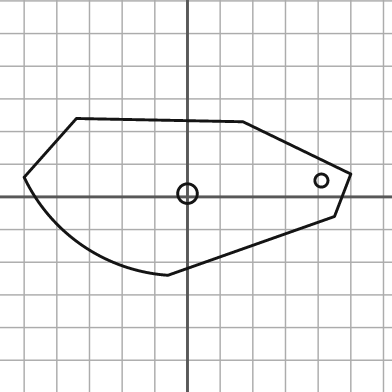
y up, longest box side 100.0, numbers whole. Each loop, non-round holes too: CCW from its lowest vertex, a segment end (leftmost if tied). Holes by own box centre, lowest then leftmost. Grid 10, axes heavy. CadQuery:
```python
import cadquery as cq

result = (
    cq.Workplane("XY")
    .moveTo(-6.0, -24.0)
    .lineTo(45.0, -6.0)
    .lineTo(50.0, 7.0)
    .lineTo(17.0, 23.0)
    .lineTo(-34.0, 24.0)
    .lineTo(-50.0, 6.0)
    .threePointArc((-32.0, -15.0), (-6.0, -24.0))
    .close()
    .moveTo(0.0, 1.0)
    .circle(3.0)
    .moveTo(41.0, 5.0)
    .circle(2.0)
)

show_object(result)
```